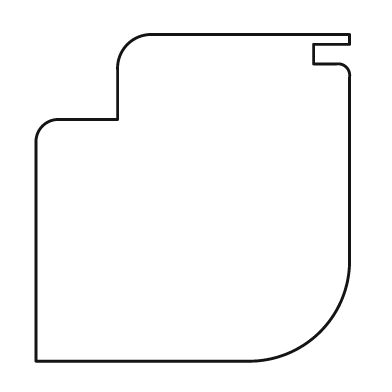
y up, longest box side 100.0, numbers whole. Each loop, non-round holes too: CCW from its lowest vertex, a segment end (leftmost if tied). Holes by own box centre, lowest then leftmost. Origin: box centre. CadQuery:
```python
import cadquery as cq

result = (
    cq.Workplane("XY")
    .moveTo(-48.0, -50.0)
    .lineTo(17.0, -50.0)
    .threePointArc((39.0, -41.0), (48.0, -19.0))
    .lineTo(48.0, 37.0)
    .threePointArc((47.0, 40.0), (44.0, 41.0))
    .lineTo(37.0, 41.0)
    .lineTo(37.0, 47.0)
    .lineTo(48.0, 47.0)
    .lineTo(48.0, 50.0)
    .lineTo(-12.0, 50.0)
    .threePointArc((-20.0, 47.0), (-23.0, 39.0))
    .lineTo(-23.0, 24.0)
    .lineTo(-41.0, 24.0)
    .threePointArc((-46.0, 22.0), (-48.0, 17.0))
    .close()
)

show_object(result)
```